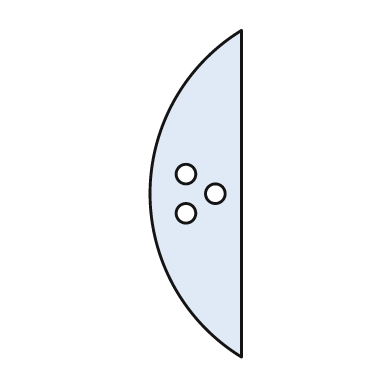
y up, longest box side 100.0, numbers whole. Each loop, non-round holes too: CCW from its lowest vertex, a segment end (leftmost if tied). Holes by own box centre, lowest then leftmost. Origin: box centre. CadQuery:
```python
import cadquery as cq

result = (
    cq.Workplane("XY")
    .moveTo(14.0, -50.0)
    .lineTo(14.0, 50.0)
    .threePointArc((-14.0, 0.0), (14.0, -50.0))
    .close()
    .moveTo(-3.0, -6.0)
    .circle(3.0)
    .moveTo(6.0, 0.0)
    .circle(3.0)
    .moveTo(-3.0, 6.0)
    .circle(3.0)
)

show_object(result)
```